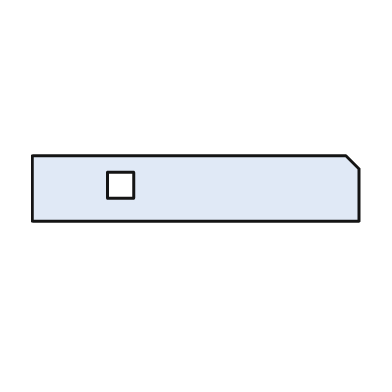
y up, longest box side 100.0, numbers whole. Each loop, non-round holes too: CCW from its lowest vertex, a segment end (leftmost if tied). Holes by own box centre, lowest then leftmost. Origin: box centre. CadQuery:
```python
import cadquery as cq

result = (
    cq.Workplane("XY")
    .moveTo(-50.0, -10.0)
    .lineTo(50.0, -10.0)
    .lineTo(50.0, 6.0)
    .lineTo(46.0, 10.0)
    .lineTo(-50.0, 10.0)
    .close()
    .moveTo(-27.0, -3.0)
    .lineTo(-19.0, -3.0)
    .lineTo(-19.0, 5.0)
    .lineTo(-27.0, 5.0)
    .close()
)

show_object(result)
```